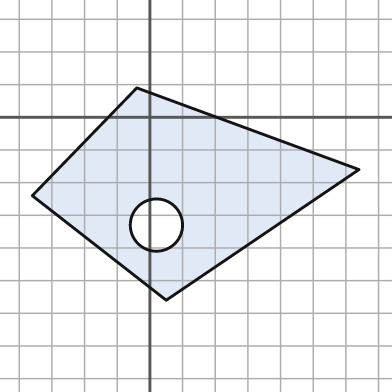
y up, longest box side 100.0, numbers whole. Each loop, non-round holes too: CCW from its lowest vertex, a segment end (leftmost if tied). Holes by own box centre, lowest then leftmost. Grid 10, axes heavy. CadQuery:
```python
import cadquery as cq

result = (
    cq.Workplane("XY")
    .moveTo(5.0, -56.0)
    .lineTo(64.0, -16.0)
    .lineTo(-4.0, 9.0)
    .lineTo(-36.0, -24.0)
    .close()
    .moveTo(2.0, -33.0)
    .circle(8.0)
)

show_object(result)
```